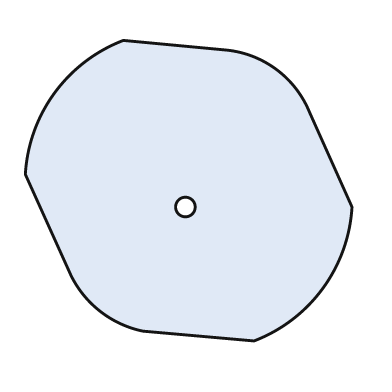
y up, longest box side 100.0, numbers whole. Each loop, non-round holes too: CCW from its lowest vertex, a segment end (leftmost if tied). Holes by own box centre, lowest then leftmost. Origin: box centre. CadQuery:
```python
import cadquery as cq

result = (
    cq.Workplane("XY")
    .moveTo(20.0, -46.0)
    .threePointArc((41.0, -30.0), (50.0, -5.0))
    .lineTo(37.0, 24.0)
    .threePointArc((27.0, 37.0), (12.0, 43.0))
    .lineTo(-20.0, 46.0)
    .threePointArc((-41.0, 30.0), (-50.0, 5.0))
    .lineTo(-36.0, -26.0)
    .threePointArc((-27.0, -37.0), (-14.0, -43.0))
    .close()
    .moveTo(-1.0, -5.0)
    .circle(3.0)
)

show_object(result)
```